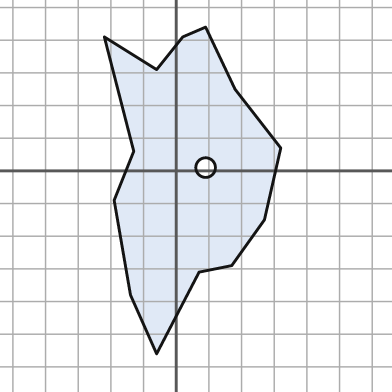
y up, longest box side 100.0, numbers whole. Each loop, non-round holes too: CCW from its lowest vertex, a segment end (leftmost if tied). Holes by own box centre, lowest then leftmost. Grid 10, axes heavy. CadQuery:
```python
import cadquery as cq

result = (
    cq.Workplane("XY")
    .moveTo(-6.0, -56.0)
    .lineTo(7.0, -31.0)
    .lineTo(17.0, -29.0)
    .lineTo(27.0, -15.0)
    .lineTo(32.0, 7.0)
    .lineTo(18.0, 25.0)
    .lineTo(9.0, 44.0)
    .lineTo(2.0, 41.0)
    .lineTo(-6.0, 31.0)
    .lineTo(-22.0, 41.0)
    .lineTo(-13.0, 6.0)
    .lineTo(-19.0, -9.0)
    .lineTo(-14.0, -38.0)
    .close()
    .moveTo(9.0, 1.0)
    .circle(3.0)
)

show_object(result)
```